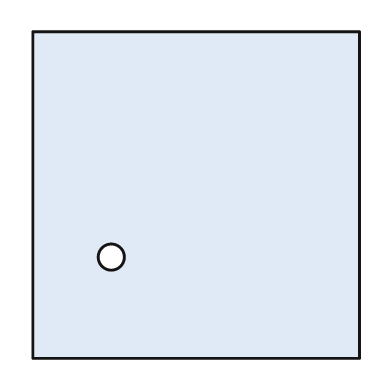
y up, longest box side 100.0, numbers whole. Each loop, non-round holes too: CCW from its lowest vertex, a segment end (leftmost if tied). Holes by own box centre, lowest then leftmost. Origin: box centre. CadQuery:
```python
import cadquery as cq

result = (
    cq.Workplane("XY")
    .moveTo(-50.0, -50.0)
    .lineTo(50.0, -50.0)
    .lineTo(50.0, 50.0)
    .lineTo(-50.0, 50.0)
    .close()
    .moveTo(-26.0, -19.0)
    .circle(4.0)
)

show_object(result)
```